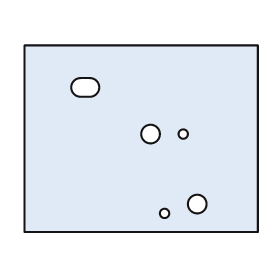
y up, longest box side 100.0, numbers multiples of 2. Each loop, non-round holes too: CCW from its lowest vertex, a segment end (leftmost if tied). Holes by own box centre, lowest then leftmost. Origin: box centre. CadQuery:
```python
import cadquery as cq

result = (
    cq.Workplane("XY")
    .moveTo(-50.0, -40.0)
    .lineTo(50.0, -40.0)
    .lineTo(50.0, 40.0)
    .lineTo(-50.0, 40.0)
    .close()
    .moveTo(10.0, -32.0)
    .circle(2.0)
    .moveTo(24.0, -28.0)
    .circle(4.0)
    .moveTo(4.0, 2.0)
    .circle(4.0)
    .moveTo(18.0, 2.0)
    .circle(2.0)
    .moveTo(-26.0, 18.0)
    .lineTo(-22.0, 18.0)
    .threePointArc((-18.0, 22.0), (-22.0, 26.0))
    .lineTo(-26.0, 26.0)
    .threePointArc((-30.0, 22.0), (-26.0, 18.0))
    .close()
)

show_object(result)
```